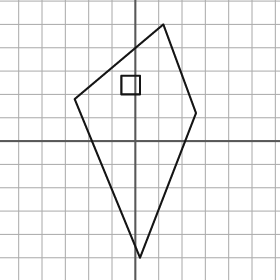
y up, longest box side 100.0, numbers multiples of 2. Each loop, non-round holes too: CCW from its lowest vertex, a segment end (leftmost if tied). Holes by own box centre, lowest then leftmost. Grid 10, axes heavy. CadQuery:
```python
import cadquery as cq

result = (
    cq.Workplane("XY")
    .moveTo(2.0, -50.0)
    .lineTo(26.0, 12.0)
    .lineTo(12.0, 50.0)
    .lineTo(-26.0, 18.0)
    .close()
    .moveTo(-6.0, 20.0)
    .lineTo(2.0, 20.0)
    .lineTo(2.0, 28.0)
    .lineTo(-6.0, 28.0)
    .close()
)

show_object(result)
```